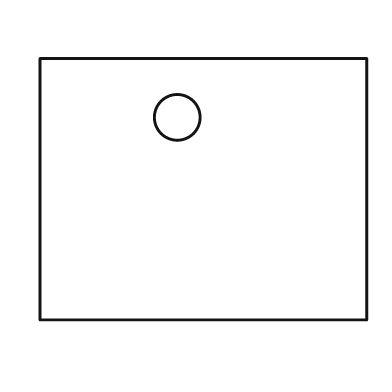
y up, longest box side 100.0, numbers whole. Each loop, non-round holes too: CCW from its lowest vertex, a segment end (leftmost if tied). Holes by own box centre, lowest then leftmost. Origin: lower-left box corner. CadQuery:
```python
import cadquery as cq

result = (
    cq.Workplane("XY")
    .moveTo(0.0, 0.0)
    .lineTo(100.0, 0.0)
    .lineTo(100.0, 80.0)
    .lineTo(0.0, 80.0)
    .close()
    .moveTo(42.0, 62.0)
    .circle(7.0)
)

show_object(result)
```